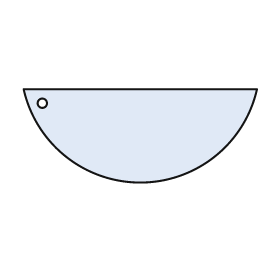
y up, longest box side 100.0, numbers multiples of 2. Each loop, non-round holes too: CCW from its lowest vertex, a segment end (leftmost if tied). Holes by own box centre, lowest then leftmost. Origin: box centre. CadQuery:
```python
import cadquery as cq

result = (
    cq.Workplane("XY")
    .moveTo(-50.0, 20.0)
    .threePointArc((0.0, -20.0), (50.0, 20.0))
    .close()
    .moveTo(-42.0, 14.0)
    .circle(2.0)
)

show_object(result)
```